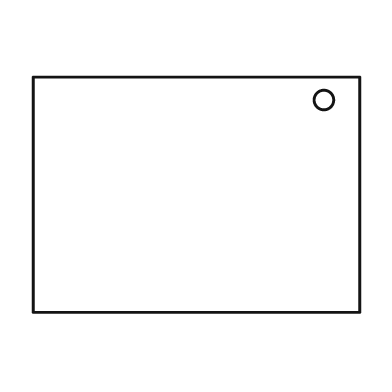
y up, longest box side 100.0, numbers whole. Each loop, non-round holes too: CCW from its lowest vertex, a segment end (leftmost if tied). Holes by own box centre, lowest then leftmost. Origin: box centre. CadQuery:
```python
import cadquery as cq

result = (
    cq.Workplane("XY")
    .moveTo(-50.0, -36.0)
    .lineTo(50.0, -36.0)
    .lineTo(50.0, 36.0)
    .lineTo(-50.0, 36.0)
    .close()
    .moveTo(39.0, 29.0)
    .circle(3.0)
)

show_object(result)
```